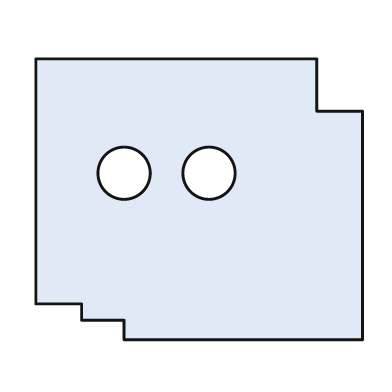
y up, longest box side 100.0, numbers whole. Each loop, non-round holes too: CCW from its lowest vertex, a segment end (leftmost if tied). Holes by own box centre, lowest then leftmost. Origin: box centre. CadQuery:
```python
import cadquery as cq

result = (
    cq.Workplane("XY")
    .moveTo(-23.0, -43.0)
    .lineTo(50.0, -43.0)
    .lineTo(50.0, 27.0)
    .lineTo(36.0, 27.0)
    .lineTo(36.0, 43.0)
    .lineTo(-50.0, 43.0)
    .lineTo(-50.0, -32.0)
    .lineTo(-36.0, -32.0)
    .lineTo(-36.0, -37.0)
    .lineTo(-23.0, -37.0)
    .close()
    .moveTo(-23.0, 8.0)
    .circle(8.0)
    .moveTo(3.0, 8.0)
    .circle(8.0)
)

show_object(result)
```